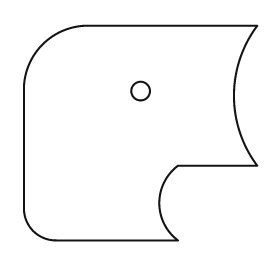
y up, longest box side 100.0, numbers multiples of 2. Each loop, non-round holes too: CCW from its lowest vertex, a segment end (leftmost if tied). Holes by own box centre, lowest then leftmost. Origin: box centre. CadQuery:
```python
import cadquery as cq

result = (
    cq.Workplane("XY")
    .moveTo(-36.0, -46.0)
    .lineTo(16.0, -46.0)
    .threePointArc((8.0, -30.0), (16.0, -14.0))
    .lineTo(50.0, -14.0)
    .threePointArc((40.0, 16.0), (50.0, 46.0))
    .lineTo(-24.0, 46.0)
    .threePointArc((-42.0, 38.0), (-50.0, 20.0))
    .lineTo(-50.0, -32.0)
    .threePointArc((-46.0, -42.0), (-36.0, -46.0))
    .close()
    .moveTo(0.0, 18.0)
    .circle(4.0)
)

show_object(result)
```